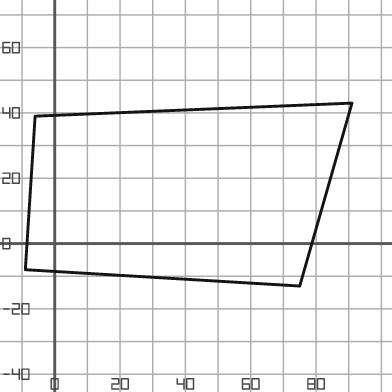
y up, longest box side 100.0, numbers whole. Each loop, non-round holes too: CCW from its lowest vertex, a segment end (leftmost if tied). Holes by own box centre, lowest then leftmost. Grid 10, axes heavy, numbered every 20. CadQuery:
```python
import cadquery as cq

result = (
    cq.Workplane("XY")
    .moveTo(75.0, -13.0)
    .lineTo(91.0, 43.0)
    .lineTo(-6.0, 39.0)
    .lineTo(-9.0, -8.0)
    .close()
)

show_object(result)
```